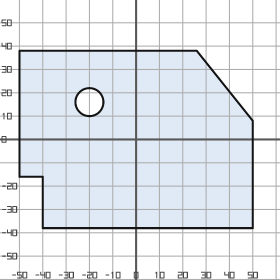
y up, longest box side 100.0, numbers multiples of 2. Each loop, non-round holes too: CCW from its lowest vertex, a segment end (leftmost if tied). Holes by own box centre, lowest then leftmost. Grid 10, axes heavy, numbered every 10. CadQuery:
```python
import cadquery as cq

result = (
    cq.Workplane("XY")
    .moveTo(-40.0, -38.0)
    .lineTo(50.0, -38.0)
    .lineTo(50.0, 8.0)
    .lineTo(26.0, 38.0)
    .lineTo(-50.0, 38.0)
    .lineTo(-50.0, -16.0)
    .lineTo(-40.0, -16.0)
    .close()
    .moveTo(-20.0, 16.0)
    .circle(6.0)
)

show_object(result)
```